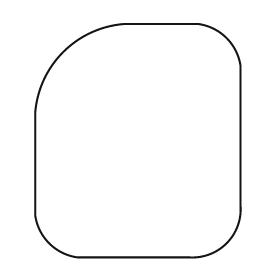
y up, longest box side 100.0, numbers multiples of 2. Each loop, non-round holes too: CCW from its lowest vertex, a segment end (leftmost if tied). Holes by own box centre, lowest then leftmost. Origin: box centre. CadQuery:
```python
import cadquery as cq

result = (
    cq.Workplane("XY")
    .moveTo(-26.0, -50.0)
    .lineTo(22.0, -50.0)
    .threePointArc((38.0, -44.0), (44.0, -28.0))
    .lineTo(44.0, 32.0)
    .threePointArc((38.0, 44.0), (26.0, 50.0))
    .lineTo(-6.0, 50.0)
    .threePointArc((-32.0, 38.0), (-44.0, 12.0))
    .lineTo(-44.0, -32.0)
    .threePointArc((-38.0, -44.0), (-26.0, -50.0))
    .close()
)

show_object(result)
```